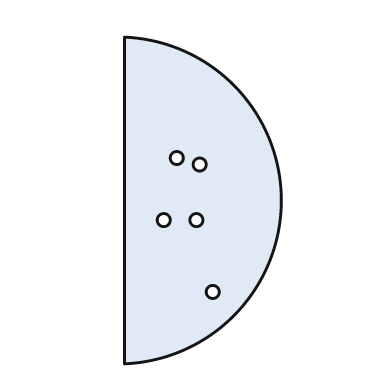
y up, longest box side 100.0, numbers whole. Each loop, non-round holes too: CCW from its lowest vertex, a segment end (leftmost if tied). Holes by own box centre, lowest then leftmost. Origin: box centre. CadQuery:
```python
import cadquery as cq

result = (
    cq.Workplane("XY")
    .moveTo(-24.0, -50.0)
    .threePointArc((24.0, 0.0), (-24.0, 50.0))
    .close()
    .moveTo(3.0, -28.0)
    .circle(2.0)
    .moveTo(-12.0, -6.0)
    .circle(2.0)
    .moveTo(-2.0, -6.0)
    .circle(2.0)
    .moveTo(-1.0, 11.0)
    .circle(2.0)
    .moveTo(-8.0, 13.0)
    .circle(2.0)
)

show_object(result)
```